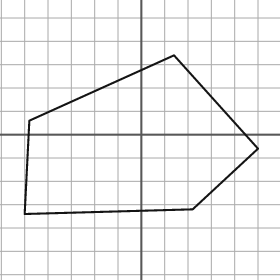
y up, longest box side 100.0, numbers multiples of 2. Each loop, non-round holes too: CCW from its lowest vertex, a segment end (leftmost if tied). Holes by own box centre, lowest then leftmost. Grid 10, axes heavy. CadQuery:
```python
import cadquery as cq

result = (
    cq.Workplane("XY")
    .moveTo(-50.0, -34.0)
    .lineTo(22.0, -32.0)
    .lineTo(50.0, -6.0)
    .lineTo(14.0, 34.0)
    .lineTo(-48.0, 6.0)
    .close()
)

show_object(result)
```